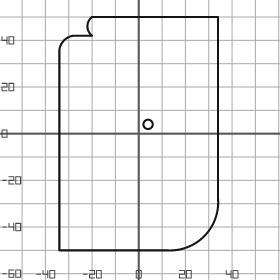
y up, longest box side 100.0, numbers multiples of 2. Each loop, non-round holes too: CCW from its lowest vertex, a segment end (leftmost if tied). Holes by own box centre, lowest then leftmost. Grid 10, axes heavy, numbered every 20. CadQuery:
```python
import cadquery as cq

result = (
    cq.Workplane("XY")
    .moveTo(-34.0, -50.0)
    .lineTo(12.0, -50.0)
    .threePointArc((28.0, -44.0), (34.0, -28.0))
    .lineTo(34.0, 50.0)
    .lineTo(-20.0, 50.0)
    .threePointArc((-22.0, 46.0), (-20.0, 42.0))
    .lineTo(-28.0, 42.0)
    .threePointArc((-32.0, 40.0), (-34.0, 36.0))
    .close()
    .moveTo(4.0, 4.0)
    .circle(2.0)
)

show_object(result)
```